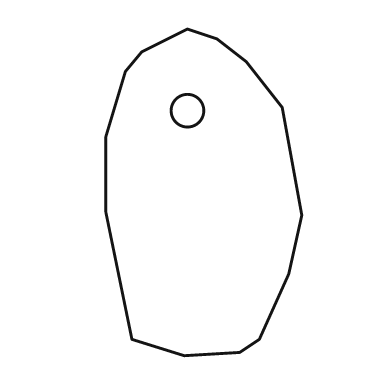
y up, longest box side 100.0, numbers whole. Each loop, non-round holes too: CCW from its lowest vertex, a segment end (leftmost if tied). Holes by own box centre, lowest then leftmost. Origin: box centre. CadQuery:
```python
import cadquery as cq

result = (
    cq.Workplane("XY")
    .moveTo(-6.0, -50.0)
    .lineTo(11.0, -49.0)
    .lineTo(17.0, -45.0)
    .lineTo(26.0, -25.0)
    .lineTo(30.0, -7.0)
    .lineTo(24.0, 26.0)
    .lineTo(13.0, 40.0)
    .lineTo(4.0, 47.0)
    .lineTo(-5.0, 50.0)
    .lineTo(-19.0, 43.0)
    .lineTo(-24.0, 37.0)
    .lineTo(-30.0, 17.0)
    .lineTo(-30.0, -6.0)
    .lineTo(-22.0, -45.0)
    .close()
    .moveTo(-5.0, 25.0)
    .circle(5.0)
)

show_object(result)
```